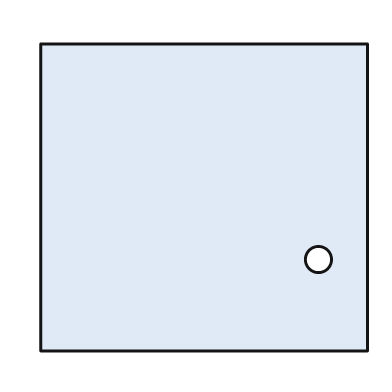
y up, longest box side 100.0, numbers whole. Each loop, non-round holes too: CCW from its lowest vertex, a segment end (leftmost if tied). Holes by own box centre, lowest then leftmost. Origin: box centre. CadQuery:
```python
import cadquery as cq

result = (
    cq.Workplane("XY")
    .moveTo(-50.0, -47.0)
    .lineTo(50.0, -47.0)
    .lineTo(50.0, 47.0)
    .lineTo(-50.0, 47.0)
    .close()
    .moveTo(35.0, -19.0)
    .circle(4.0)
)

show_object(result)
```